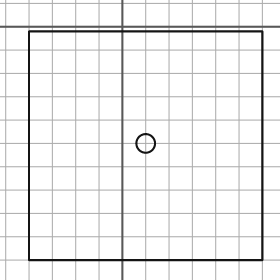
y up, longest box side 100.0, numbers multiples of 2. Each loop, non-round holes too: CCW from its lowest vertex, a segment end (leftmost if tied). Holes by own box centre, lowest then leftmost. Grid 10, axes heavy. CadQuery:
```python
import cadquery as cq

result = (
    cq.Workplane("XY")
    .moveTo(-40.0, -100.0)
    .lineTo(60.0, -100.0)
    .lineTo(60.0, -2.0)
    .lineTo(-40.0, -2.0)
    .close()
    .moveTo(10.0, -50.0)
    .circle(4.0)
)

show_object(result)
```